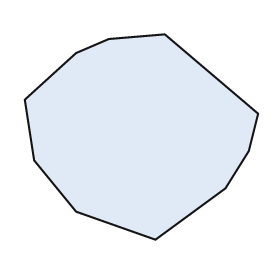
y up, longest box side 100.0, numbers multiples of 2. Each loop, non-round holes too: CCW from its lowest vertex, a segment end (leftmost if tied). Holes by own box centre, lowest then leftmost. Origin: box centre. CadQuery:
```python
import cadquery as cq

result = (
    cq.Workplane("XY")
    .moveTo(6.0, -44.0)
    .lineTo(36.0, -22.0)
    .lineTo(46.0, -6.0)
    .lineTo(50.0, 10.0)
    .lineTo(10.0, 44.0)
    .lineTo(-14.0, 42.0)
    .lineTo(-28.0, 36.0)
    .lineTo(-50.0, 16.0)
    .lineTo(-46.0, -10.0)
    .lineTo(-28.0, -32.0)
    .close()
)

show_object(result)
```